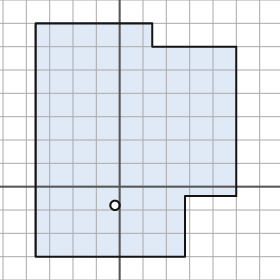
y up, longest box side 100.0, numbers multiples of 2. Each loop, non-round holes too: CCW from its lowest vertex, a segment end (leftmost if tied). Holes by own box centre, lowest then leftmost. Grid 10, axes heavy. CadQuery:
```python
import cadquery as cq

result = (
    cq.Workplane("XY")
    .moveTo(-36.0, -30.0)
    .lineTo(28.0, -30.0)
    .lineTo(28.0, -4.0)
    .lineTo(50.0, -4.0)
    .lineTo(50.0, 60.0)
    .lineTo(14.0, 60.0)
    .lineTo(14.0, 70.0)
    .lineTo(-36.0, 70.0)
    .close()
    .moveTo(-2.0, -8.0)
    .circle(2.0)
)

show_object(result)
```